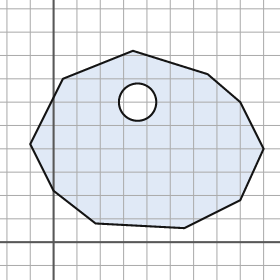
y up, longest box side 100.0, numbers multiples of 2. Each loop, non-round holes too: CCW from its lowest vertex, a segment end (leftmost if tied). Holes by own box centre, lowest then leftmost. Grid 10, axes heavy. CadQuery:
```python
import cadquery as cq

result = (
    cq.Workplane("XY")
    .moveTo(56.0, 6.0)
    .lineTo(80.0, 18.0)
    .lineTo(90.0, 40.0)
    .lineTo(80.0, 60.0)
    .lineTo(66.0, 72.0)
    .lineTo(34.0, 82.0)
    .lineTo(4.0, 70.0)
    .lineTo(-10.0, 42.0)
    .lineTo(0.0, 22.0)
    .lineTo(18.0, 8.0)
    .close()
    .moveTo(36.0, 60.0)
    .circle(8.0)
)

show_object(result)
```